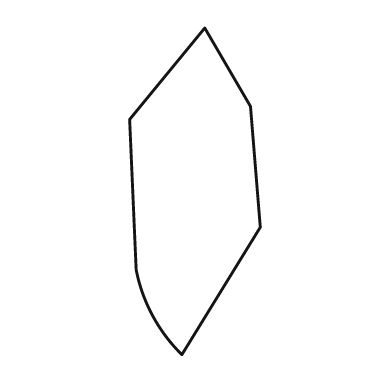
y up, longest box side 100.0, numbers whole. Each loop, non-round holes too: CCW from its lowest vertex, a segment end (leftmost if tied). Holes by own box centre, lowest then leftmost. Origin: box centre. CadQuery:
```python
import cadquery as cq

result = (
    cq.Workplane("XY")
    .moveTo(-4.0, -50.0)
    .lineTo(20.0, -11.0)
    .lineTo(17.0, 26.0)
    .lineTo(3.0, 50.0)
    .lineTo(-20.0, 22.0)
    .lineTo(-18.0, -24.0)
    .threePointArc((-13.0, -38.0), (-4.0, -50.0))
    .close()
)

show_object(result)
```